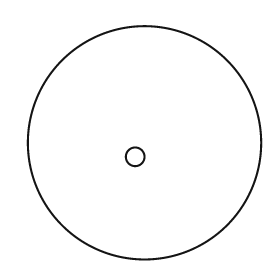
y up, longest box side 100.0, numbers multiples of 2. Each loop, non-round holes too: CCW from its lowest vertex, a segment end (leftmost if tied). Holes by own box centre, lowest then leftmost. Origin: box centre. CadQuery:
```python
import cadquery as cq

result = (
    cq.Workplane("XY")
    .moveTo(0.0, 0.0)
    .circle(50.0)
    .moveTo(-4.0, -6.0)
    .circle(4.0)
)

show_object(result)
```